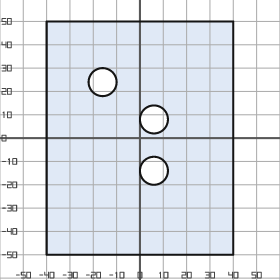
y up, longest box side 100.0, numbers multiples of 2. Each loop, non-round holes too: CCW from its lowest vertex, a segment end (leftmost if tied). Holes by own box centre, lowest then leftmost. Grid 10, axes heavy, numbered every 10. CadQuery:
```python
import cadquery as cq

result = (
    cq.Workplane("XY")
    .moveTo(-40.0, -50.0)
    .lineTo(40.0, -50.0)
    .lineTo(40.0, 50.0)
    .lineTo(-40.0, 50.0)
    .close()
    .moveTo(6.0, -14.0)
    .circle(6.0)
    .moveTo(6.0, 8.0)
    .circle(6.0)
    .moveTo(-16.0, 24.0)
    .circle(6.0)
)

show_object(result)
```